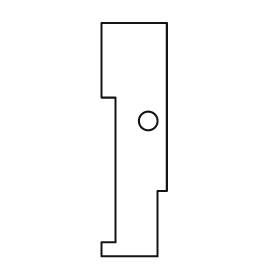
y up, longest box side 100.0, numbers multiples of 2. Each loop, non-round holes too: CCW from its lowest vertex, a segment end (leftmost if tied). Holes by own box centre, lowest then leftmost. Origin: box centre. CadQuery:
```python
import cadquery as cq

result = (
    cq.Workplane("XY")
    .moveTo(-14.0, -50.0)
    .lineTo(10.0, -50.0)
    .lineTo(10.0, -22.0)
    .lineTo(14.0, -22.0)
    .lineTo(14.0, 50.0)
    .lineTo(-14.0, 50.0)
    .lineTo(-14.0, 18.0)
    .lineTo(-8.0, 18.0)
    .lineTo(-8.0, -44.0)
    .lineTo(-14.0, -44.0)
    .close()
    .moveTo(6.0, 8.0)
    .circle(4.0)
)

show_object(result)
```